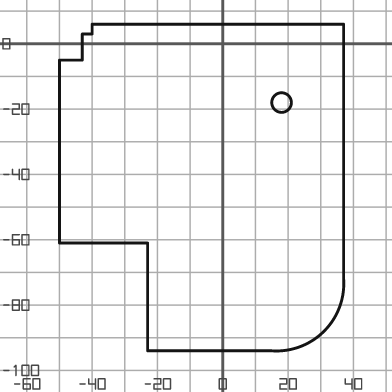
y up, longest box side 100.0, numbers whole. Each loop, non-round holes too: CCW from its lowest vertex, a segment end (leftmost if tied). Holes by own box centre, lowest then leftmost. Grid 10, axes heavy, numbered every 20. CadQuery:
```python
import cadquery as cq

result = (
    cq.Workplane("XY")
    .moveTo(-23.0, -94.0)
    .lineTo(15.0, -94.0)
    .threePointArc((31.0, -88.0), (37.0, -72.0))
    .lineTo(37.0, 6.0)
    .lineTo(-40.0, 6.0)
    .lineTo(-40.0, 3.0)
    .lineTo(-43.0, 3.0)
    .lineTo(-43.0, -5.0)
    .lineTo(-50.0, -5.0)
    .lineTo(-50.0, -61.0)
    .lineTo(-23.0, -61.0)
    .close()
    .moveTo(18.0, -18.0)
    .circle(3.0)
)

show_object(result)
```